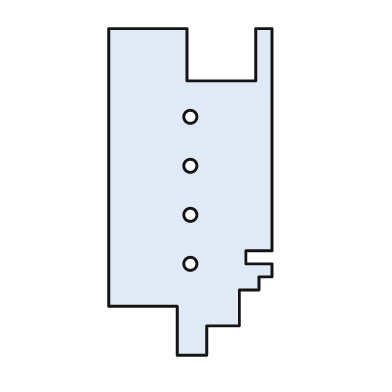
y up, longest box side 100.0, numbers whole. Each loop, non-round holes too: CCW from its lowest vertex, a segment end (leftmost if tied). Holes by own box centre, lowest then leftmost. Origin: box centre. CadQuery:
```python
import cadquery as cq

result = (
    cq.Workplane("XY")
    .moveTo(-4.0, -50.0)
    .lineTo(5.0, -50.0)
    .lineTo(5.0, -41.0)
    .lineTo(15.0, -41.0)
    .lineTo(15.0, -30.0)
    .lineTo(21.0, -30.0)
    .lineTo(21.0, -26.0)
    .lineTo(25.0, -26.0)
    .lineTo(25.0, -22.0)
    .lineTo(17.0, -22.0)
    .lineTo(17.0, -18.0)
    .lineTo(25.0, -18.0)
    .lineTo(25.0, 50.0)
    .lineTo(20.0, 50.0)
    .lineTo(20.0, 34.0)
    .lineTo(-1.0, 34.0)
    .lineTo(-1.0, 50.0)
    .lineTo(-25.0, 50.0)
    .lineTo(-25.0, -35.0)
    .lineTo(-4.0, -35.0)
    .close()
    .moveTo(0.0, -22.0)
    .circle(2.0)
    .moveTo(0.0, -7.0)
    .circle(2.0)
    .moveTo(0.0, 8.0)
    .circle(2.0)
    .moveTo(0.0, 23.0)
    .circle(2.0)
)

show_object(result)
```